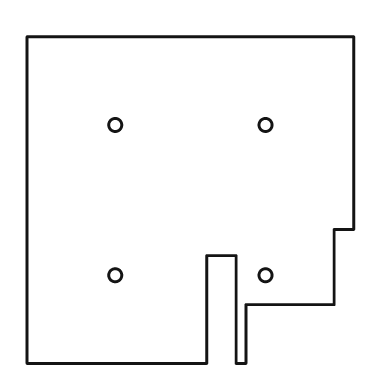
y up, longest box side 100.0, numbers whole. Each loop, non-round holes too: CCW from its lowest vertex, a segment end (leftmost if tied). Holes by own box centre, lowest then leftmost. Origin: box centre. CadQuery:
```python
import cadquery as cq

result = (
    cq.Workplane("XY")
    .moveTo(-50.0, -50.0)
    .lineTo(5.0, -50.0)
    .lineTo(5.0, -17.0)
    .lineTo(14.0, -17.0)
    .lineTo(14.0, -50.0)
    .lineTo(17.0, -50.0)
    .lineTo(17.0, -32.0)
    .lineTo(44.0, -32.0)
    .lineTo(44.0, -9.0)
    .lineTo(50.0, -9.0)
    .lineTo(50.0, 50.0)
    .lineTo(-50.0, 50.0)
    .close()
    .moveTo(-23.0, -23.0)
    .circle(2.0)
    .moveTo(23.0, -23.0)
    .circle(2.0)
    .moveTo(-23.0, 23.0)
    .circle(2.0)
    .moveTo(23.0, 23.0)
    .circle(2.0)
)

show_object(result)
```